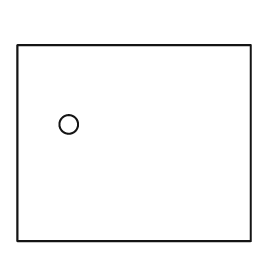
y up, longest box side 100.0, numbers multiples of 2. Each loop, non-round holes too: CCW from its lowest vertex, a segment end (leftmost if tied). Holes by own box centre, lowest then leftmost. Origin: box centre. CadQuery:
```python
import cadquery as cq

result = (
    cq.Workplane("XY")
    .moveTo(-50.0, -42.0)
    .lineTo(50.0, -42.0)
    .lineTo(50.0, 42.0)
    .lineTo(-50.0, 42.0)
    .close()
    .moveTo(-28.0, 8.0)
    .circle(4.0)
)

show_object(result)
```